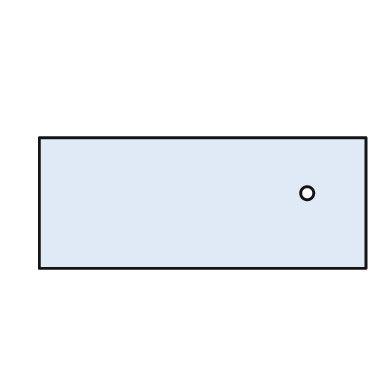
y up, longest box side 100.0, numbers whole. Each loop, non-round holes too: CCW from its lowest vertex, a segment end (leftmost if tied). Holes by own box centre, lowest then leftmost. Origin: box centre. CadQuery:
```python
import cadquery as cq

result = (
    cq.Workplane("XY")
    .moveTo(-50.0, -20.0)
    .lineTo(50.0, -20.0)
    .lineTo(50.0, 20.0)
    .lineTo(-50.0, 20.0)
    .close()
    .moveTo(32.0, 3.0)
    .circle(2.0)
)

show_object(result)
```